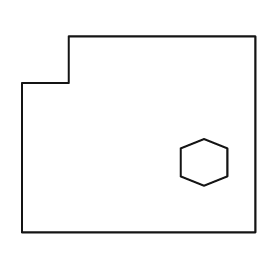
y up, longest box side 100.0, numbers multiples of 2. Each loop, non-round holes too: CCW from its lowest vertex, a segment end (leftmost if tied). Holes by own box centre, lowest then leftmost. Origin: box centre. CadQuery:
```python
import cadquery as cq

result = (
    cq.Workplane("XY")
    .moveTo(-50.0, -42.0)
    .lineTo(50.0, -42.0)
    .lineTo(50.0, 42.0)
    .lineTo(-30.0, 42.0)
    .lineTo(-30.0, 22.0)
    .lineTo(-50.0, 22.0)
    .close()
    .moveTo(28.0, -22.0)
    .lineTo(38.0, -18.0)
    .lineTo(38.0, -6.0)
    .lineTo(28.0, -2.0)
    .lineTo(18.0, -6.0)
    .lineTo(18.0, -18.0)
    .close()
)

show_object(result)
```